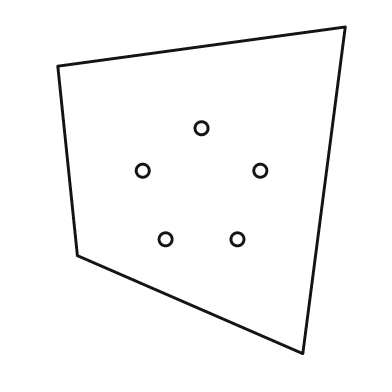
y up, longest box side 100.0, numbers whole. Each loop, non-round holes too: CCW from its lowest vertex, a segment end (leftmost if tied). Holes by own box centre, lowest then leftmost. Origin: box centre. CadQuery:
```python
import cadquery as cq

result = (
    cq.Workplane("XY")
    .moveTo(31.0, -50.0)
    .lineTo(44.0, 50.0)
    .lineTo(-44.0, 38.0)
    .lineTo(-38.0, -20.0)
    .close()
    .moveTo(-11.0, -15.0)
    .circle(2.0)
    .moveTo(11.0, -15.0)
    .circle(2.0)
    .moveTo(-18.0, 6.0)
    .circle(2.0)
    .moveTo(18.0, 6.0)
    .circle(2.0)
    .moveTo(0.0, 19.0)
    .circle(2.0)
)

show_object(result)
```